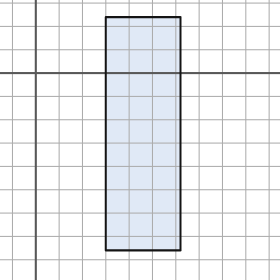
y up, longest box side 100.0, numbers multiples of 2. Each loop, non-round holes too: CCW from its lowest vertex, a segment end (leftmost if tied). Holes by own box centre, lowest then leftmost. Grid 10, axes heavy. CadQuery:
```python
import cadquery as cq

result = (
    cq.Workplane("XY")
    .moveTo(30.0, -76.0)
    .lineTo(62.0, -76.0)
    .lineTo(62.0, 24.0)
    .lineTo(30.0, 24.0)
    .close()
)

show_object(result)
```